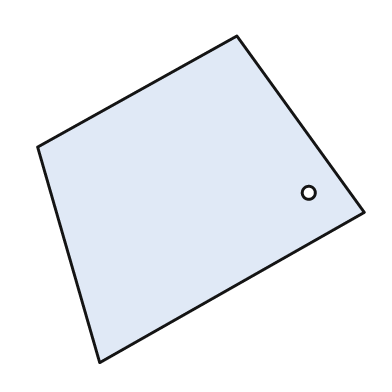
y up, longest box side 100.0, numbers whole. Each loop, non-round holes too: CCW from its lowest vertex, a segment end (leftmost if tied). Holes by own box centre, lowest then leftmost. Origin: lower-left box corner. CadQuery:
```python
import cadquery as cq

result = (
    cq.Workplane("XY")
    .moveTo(19.0, 0.0)
    .lineTo(100.0, 46.0)
    .lineTo(61.0, 100.0)
    .lineTo(0.0, 66.0)
    .close()
    .moveTo(83.0, 52.0)
    .circle(2.0)
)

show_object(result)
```